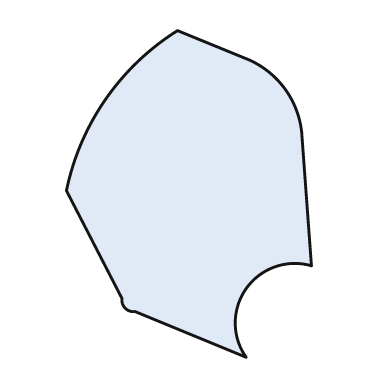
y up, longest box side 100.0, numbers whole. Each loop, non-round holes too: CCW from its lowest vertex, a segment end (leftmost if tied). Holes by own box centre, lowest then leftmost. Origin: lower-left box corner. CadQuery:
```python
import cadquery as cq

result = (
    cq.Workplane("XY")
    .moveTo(55.0, 0.0)
    .threePointArc((55.0, 21.0), (75.0, 28.0))
    .lineTo(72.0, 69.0)
    .threePointArc((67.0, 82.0), (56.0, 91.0))
    .lineTo(34.0, 100.0)
    .threePointArc((12.0, 79.0), (0.0, 51.0))
    .lineTo(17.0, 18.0)
    .threePointArc((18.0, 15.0), (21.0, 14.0))
    .close()
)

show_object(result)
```